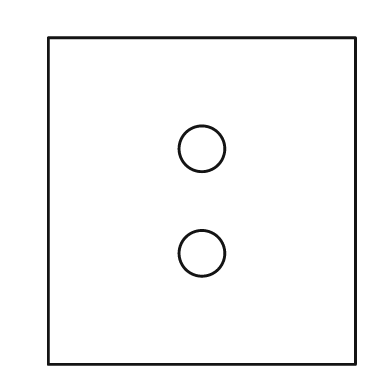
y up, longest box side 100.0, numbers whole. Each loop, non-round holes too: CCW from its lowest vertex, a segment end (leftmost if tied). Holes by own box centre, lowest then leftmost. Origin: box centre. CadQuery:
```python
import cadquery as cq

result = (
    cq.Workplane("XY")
    .moveTo(-47.0, -50.0)
    .lineTo(47.0, -50.0)
    .lineTo(47.0, 50.0)
    .lineTo(-47.0, 50.0)
    .close()
    .moveTo(0.0, -16.0)
    .circle(7.0)
    .moveTo(0.0, 16.0)
    .circle(7.0)
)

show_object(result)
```